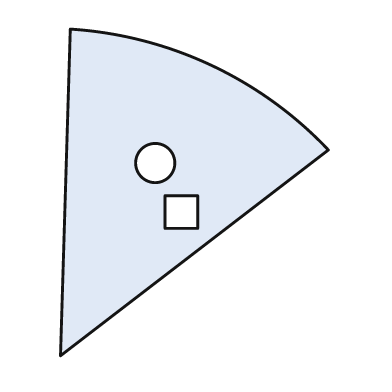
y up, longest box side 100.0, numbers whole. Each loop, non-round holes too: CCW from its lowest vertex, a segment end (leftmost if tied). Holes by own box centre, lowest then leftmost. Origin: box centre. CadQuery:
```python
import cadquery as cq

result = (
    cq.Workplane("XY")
    .moveTo(-41.0, -50.0)
    .lineTo(41.0, 13.0)
    .threePointArc((5.0, 39.0), (-38.0, 50.0))
    .close()
    .moveTo(-9.0, -11.0)
    .lineTo(1.0, -11.0)
    .lineTo(1.0, -1.0)
    .lineTo(-9.0, -1.0)
    .close()
    .moveTo(-12.0, 9.0)
    .circle(6.0)
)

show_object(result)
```